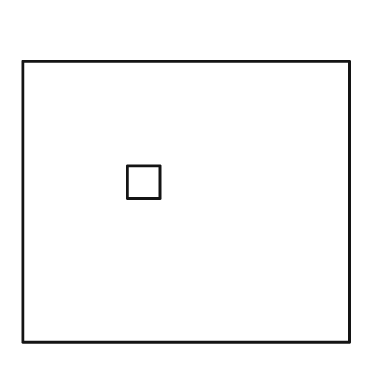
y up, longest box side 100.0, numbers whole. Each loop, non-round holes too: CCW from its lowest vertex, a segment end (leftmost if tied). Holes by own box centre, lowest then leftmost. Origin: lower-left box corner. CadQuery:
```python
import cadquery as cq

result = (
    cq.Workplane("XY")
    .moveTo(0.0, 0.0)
    .lineTo(100.0, 0.0)
    .lineTo(100.0, 86.0)
    .lineTo(0.0, 86.0)
    .close()
    .moveTo(32.0, 44.0)
    .lineTo(42.0, 44.0)
    .lineTo(42.0, 54.0)
    .lineTo(32.0, 54.0)
    .close()
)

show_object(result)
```